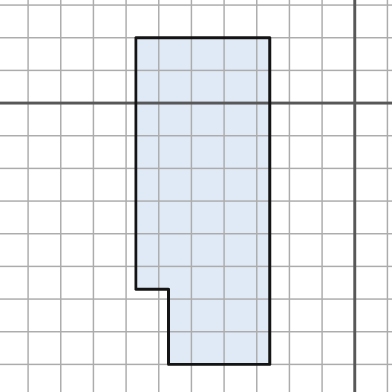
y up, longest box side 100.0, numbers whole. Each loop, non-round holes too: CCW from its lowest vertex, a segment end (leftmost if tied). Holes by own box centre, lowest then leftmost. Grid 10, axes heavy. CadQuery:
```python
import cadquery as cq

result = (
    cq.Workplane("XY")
    .moveTo(-57.0, -80.0)
    .lineTo(-26.0, -80.0)
    .lineTo(-26.0, 20.0)
    .lineTo(-67.0, 20.0)
    .lineTo(-67.0, -57.0)
    .lineTo(-57.0, -57.0)
    .close()
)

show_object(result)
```